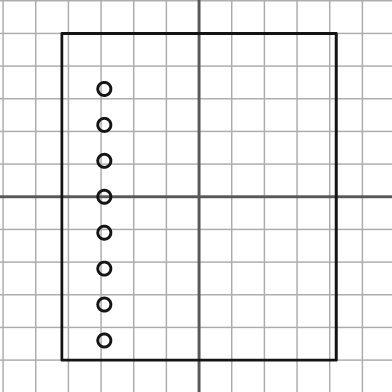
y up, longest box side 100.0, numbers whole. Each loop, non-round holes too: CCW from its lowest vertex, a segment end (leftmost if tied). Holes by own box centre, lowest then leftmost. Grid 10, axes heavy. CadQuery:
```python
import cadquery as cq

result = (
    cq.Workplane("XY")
    .moveTo(-42.0, -50.0)
    .lineTo(42.0, -50.0)
    .lineTo(42.0, 50.0)
    .lineTo(-42.0, 50.0)
    .close()
    .moveTo(-29.0, -44.0)
    .circle(2.0)
    .moveTo(-29.0, -33.0)
    .circle(2.0)
    .moveTo(-29.0, -22.0)
    .circle(2.0)
    .moveTo(-29.0, -11.0)
    .circle(2.0)
    .moveTo(-29.0, 0.0)
    .circle(2.0)
    .moveTo(-29.0, 11.0)
    .circle(2.0)
    .moveTo(-29.0, 22.0)
    .circle(2.0)
    .moveTo(-29.0, 33.0)
    .circle(2.0)
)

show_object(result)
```